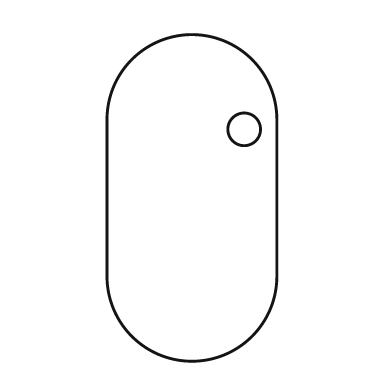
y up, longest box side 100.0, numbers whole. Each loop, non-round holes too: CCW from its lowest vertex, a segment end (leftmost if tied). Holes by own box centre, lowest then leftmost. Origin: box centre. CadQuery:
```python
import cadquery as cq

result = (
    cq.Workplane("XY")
    .moveTo(-26.0, -24.0)
    .threePointArc((0.0, -50.0), (26.0, -24.0))
    .lineTo(26.0, 24.0)
    .threePointArc((0.0, 50.0), (-26.0, 24.0))
    .close()
    .moveTo(16.0, 21.0)
    .circle(5.0)
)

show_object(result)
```